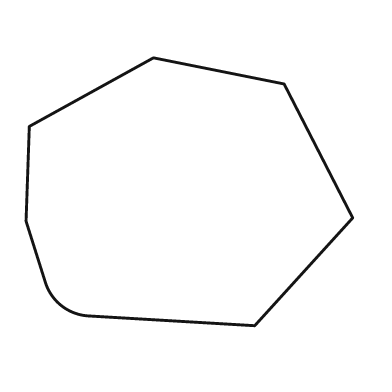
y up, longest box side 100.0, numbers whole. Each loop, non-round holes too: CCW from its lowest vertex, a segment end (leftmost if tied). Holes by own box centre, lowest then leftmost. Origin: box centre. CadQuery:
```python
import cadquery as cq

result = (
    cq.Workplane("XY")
    .moveTo(20.0, -41.0)
    .lineTo(50.0, -8.0)
    .lineTo(29.0, 33.0)
    .lineTo(-11.0, 41.0)
    .lineTo(-49.0, 20.0)
    .lineTo(-50.0, -9.0)
    .lineTo(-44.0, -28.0)
    .threePointArc((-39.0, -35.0), (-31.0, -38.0))
    .close()
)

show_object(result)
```